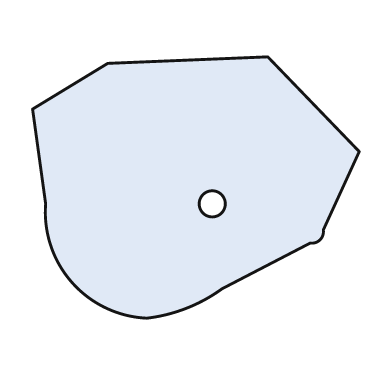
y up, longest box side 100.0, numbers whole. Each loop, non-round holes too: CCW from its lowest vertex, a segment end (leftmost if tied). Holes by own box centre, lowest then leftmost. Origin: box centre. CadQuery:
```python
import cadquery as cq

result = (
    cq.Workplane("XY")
    .moveTo(-15.0, -40.0)
    .threePointArc((-3.0, -37.0), (8.0, -31.0))
    .lineTo(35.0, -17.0)
    .threePointArc((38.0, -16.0), (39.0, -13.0))
    .lineTo(50.0, 11.0)
    .lineTo(22.0, 40.0)
    .lineTo(-27.0, 38.0)
    .lineTo(-50.0, 24.0)
    .lineTo(-46.0, -5.0)
    .threePointArc((-38.0, -29.0), (-15.0, -40.0))
    .close()
    .moveTo(5.0, -5.0)
    .circle(4.0)
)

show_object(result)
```